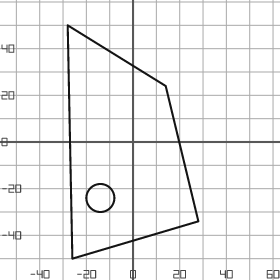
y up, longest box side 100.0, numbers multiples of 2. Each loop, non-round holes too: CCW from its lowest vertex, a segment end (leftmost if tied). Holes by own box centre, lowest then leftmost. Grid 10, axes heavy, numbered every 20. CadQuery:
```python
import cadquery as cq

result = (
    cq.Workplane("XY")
    .moveTo(-26.0, -50.0)
    .lineTo(28.0, -34.0)
    .lineTo(14.0, 24.0)
    .lineTo(-28.0, 50.0)
    .close()
    .moveTo(-14.0, -24.0)
    .circle(6.0)
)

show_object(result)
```